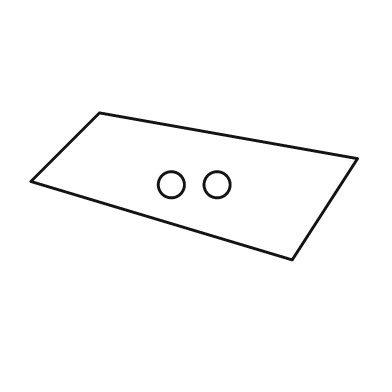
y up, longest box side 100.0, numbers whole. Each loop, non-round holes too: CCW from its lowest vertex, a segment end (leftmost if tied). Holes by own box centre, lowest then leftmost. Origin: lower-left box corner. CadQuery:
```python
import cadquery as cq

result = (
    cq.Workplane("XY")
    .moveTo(80.0, 0.0)
    .lineTo(100.0, 31.0)
    .lineTo(21.0, 45.0)
    .lineTo(0.0, 24.0)
    .close()
    .moveTo(43.0, 23.0)
    .circle(4.0)
    .moveTo(57.0, 23.0)
    .circle(4.0)
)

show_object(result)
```